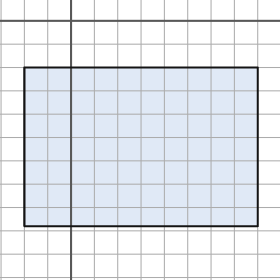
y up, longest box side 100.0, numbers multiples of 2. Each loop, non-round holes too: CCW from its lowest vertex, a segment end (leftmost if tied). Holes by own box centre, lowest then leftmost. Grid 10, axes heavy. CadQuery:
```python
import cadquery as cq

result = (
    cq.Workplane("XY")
    .moveTo(-20.0, -88.0)
    .lineTo(80.0, -88.0)
    .lineTo(80.0, -20.0)
    .lineTo(-20.0, -20.0)
    .close()
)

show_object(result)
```